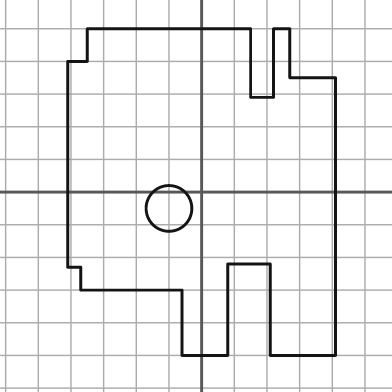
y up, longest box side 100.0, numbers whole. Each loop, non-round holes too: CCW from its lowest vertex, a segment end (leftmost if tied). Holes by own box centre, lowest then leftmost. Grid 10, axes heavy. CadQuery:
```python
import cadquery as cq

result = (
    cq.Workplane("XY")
    .moveTo(-6.0, -50.0)
    .lineTo(8.0, -50.0)
    .lineTo(8.0, -22.0)
    .lineTo(21.0, -22.0)
    .lineTo(21.0, -50.0)
    .lineTo(41.0, -50.0)
    .lineTo(41.0, 35.0)
    .lineTo(27.0, 35.0)
    .lineTo(27.0, 50.0)
    .lineTo(22.0, 50.0)
    .lineTo(22.0, 29.0)
    .lineTo(15.0, 29.0)
    .lineTo(15.0, 50.0)
    .lineTo(-35.0, 50.0)
    .lineTo(-35.0, 40.0)
    .lineTo(-41.0, 40.0)
    .lineTo(-41.0, -23.0)
    .lineTo(-37.0, -23.0)
    .lineTo(-37.0, -30.0)
    .lineTo(-6.0, -30.0)
    .close()
    .moveTo(-10.0, -5.0)
    .circle(7.0)
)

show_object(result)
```